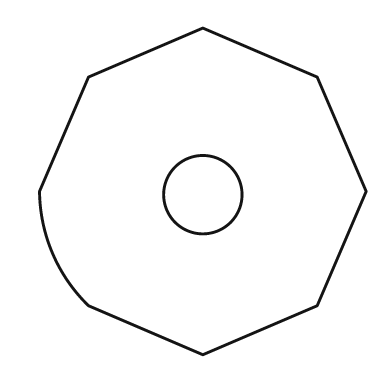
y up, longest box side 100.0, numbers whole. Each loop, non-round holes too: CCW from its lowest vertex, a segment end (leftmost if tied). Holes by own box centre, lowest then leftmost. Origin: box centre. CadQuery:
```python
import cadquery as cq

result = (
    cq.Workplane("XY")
    .moveTo(0.0, -50.0)
    .lineTo(35.0, -35.0)
    .lineTo(50.0, 0.0)
    .lineTo(35.0, 35.0)
    .lineTo(0.0, 50.0)
    .lineTo(-35.0, 35.0)
    .lineTo(-50.0, 0.0)
    .threePointArc((-46.0, -19.0), (-35.0, -35.0))
    .close()
    .moveTo(0.0, -1.0)
    .circle(12.0)
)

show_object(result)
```